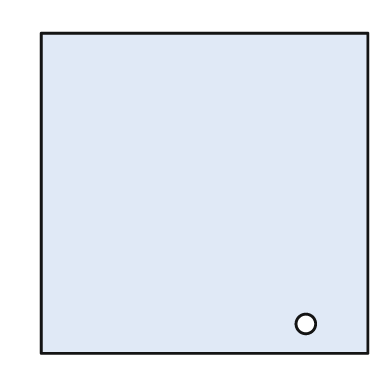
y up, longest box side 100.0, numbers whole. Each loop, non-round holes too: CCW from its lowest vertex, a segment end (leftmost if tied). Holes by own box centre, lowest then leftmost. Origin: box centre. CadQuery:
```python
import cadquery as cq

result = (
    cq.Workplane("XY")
    .moveTo(-50.0, -49.0)
    .lineTo(50.0, -49.0)
    .lineTo(50.0, 49.0)
    .lineTo(-50.0, 49.0)
    .close()
    .moveTo(31.0, -40.0)
    .circle(3.0)
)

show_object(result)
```